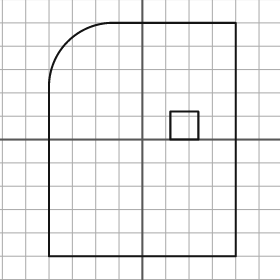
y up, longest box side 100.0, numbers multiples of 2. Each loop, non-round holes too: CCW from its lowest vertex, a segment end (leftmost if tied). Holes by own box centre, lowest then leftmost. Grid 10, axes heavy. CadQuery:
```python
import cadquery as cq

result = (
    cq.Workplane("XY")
    .moveTo(-40.0, -50.0)
    .lineTo(40.0, -50.0)
    .lineTo(40.0, 50.0)
    .lineTo(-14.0, 50.0)
    .threePointArc((-32.0, 42.0), (-40.0, 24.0))
    .close()
    .moveTo(12.0, 0.0)
    .lineTo(24.0, 0.0)
    .lineTo(24.0, 12.0)
    .lineTo(12.0, 12.0)
    .close()
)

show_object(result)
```